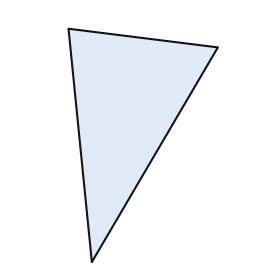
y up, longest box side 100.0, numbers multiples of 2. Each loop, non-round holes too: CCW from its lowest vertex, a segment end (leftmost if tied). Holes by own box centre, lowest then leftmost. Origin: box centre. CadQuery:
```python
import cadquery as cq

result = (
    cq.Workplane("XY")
    .moveTo(-22.0, -50.0)
    .lineTo(32.0, 42.0)
    .lineTo(-32.0, 50.0)
    .close()
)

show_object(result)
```